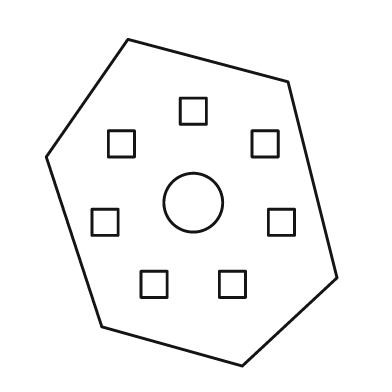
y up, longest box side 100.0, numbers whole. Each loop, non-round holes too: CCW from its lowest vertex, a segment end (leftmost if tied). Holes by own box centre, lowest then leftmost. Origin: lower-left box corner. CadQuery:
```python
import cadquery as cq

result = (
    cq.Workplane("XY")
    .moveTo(60.0, 0.0)
    .lineTo(89.0, 27.0)
    .lineTo(74.0, 87.0)
    .lineTo(25.0, 100.0)
    .lineTo(0.0, 64.0)
    .lineTo(17.0, 12.0)
    .close()
    .moveTo(29.0, 21.0)
    .lineTo(37.0, 21.0)
    .lineTo(37.0, 29.0)
    .lineTo(29.0, 29.0)
    .close()
    .moveTo(53.0, 21.0)
    .lineTo(61.0, 21.0)
    .lineTo(61.0, 29.0)
    .lineTo(53.0, 29.0)
    .close()
    .moveTo(14.0, 40.0)
    .lineTo(22.0, 40.0)
    .lineTo(22.0, 48.0)
    .lineTo(14.0, 48.0)
    .close()
    .moveTo(68.0, 40.0)
    .lineTo(76.0, 40.0)
    .lineTo(76.0, 48.0)
    .lineTo(68.0, 48.0)
    .close()
    .moveTo(45.0, 50.0)
    .circle(9.0)
    .moveTo(19.0, 64.0)
    .lineTo(27.0, 64.0)
    .lineTo(27.0, 72.0)
    .lineTo(19.0, 72.0)
    .close()
    .moveTo(63.0, 64.0)
    .lineTo(71.0, 64.0)
    .lineTo(71.0, 72.0)
    .lineTo(63.0, 72.0)
    .close()
    .moveTo(41.0, 74.0)
    .lineTo(49.0, 74.0)
    .lineTo(49.0, 82.0)
    .lineTo(41.0, 82.0)
    .close()
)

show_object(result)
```